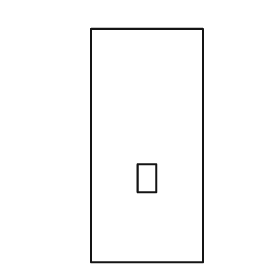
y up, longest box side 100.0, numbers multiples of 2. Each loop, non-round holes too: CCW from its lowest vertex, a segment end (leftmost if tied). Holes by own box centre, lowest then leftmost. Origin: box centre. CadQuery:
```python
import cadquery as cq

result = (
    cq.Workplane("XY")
    .moveTo(-24.0, -50.0)
    .lineTo(24.0, -50.0)
    .lineTo(24.0, 50.0)
    .lineTo(-24.0, 50.0)
    .close()
    .moveTo(-4.0, -20.0)
    .lineTo(4.0, -20.0)
    .lineTo(4.0, -8.0)
    .lineTo(-4.0, -8.0)
    .close()
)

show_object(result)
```